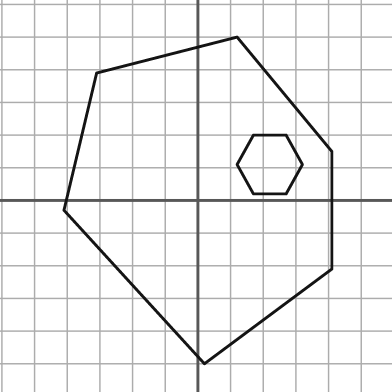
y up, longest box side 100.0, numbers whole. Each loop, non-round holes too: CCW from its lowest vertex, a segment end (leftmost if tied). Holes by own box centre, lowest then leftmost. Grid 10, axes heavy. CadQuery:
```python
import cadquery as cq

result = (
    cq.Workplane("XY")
    .moveTo(2.0, -50.0)
    .lineTo(41.0, -21.0)
    .lineTo(41.0, 15.0)
    .lineTo(12.0, 50.0)
    .lineTo(-31.0, 39.0)
    .lineTo(-41.0, -3.0)
    .close()
    .moveTo(17.0, 2.0)
    .lineTo(27.0, 2.0)
    .lineTo(32.0, 11.0)
    .lineTo(27.0, 20.0)
    .lineTo(17.0, 20.0)
    .lineTo(12.0, 11.0)
    .close()
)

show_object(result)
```